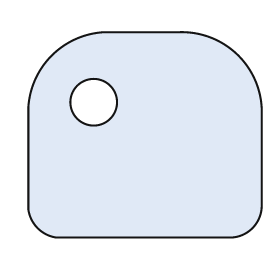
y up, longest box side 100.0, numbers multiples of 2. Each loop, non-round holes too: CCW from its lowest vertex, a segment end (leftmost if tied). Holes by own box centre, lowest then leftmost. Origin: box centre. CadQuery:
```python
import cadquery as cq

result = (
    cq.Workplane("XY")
    .moveTo(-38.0, -44.0)
    .lineTo(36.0, -44.0)
    .threePointArc((46.0, -40.0), (50.0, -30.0))
    .lineTo(50.0, 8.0)
    .threePointArc((40.0, 34.0), (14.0, 44.0))
    .lineTo(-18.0, 44.0)
    .threePointArc((-40.0, 34.0), (-50.0, 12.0))
    .lineTo(-50.0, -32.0)
    .threePointArc((-46.0, -40.0), (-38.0, -44.0))
    .close()
    .moveTo(-22.0, 14.0)
    .circle(10.0)
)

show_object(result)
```